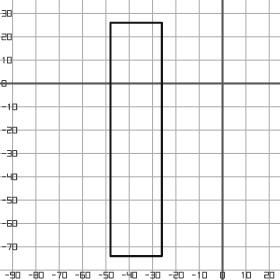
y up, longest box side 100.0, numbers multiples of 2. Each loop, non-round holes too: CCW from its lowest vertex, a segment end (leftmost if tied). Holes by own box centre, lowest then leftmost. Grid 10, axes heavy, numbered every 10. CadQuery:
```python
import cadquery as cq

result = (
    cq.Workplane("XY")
    .moveTo(-48.0, -74.0)
    .lineTo(-26.0, -74.0)
    .lineTo(-26.0, 26.0)
    .lineTo(-48.0, 26.0)
    .close()
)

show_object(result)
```